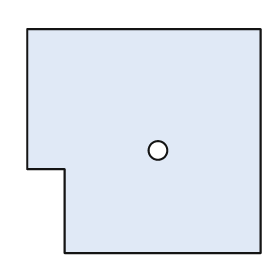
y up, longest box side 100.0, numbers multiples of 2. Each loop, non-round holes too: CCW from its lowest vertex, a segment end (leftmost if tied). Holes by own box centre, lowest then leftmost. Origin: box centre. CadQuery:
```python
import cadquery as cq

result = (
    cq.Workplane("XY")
    .moveTo(-34.0, -48.0)
    .lineTo(50.0, -48.0)
    .lineTo(50.0, 48.0)
    .lineTo(-50.0, 48.0)
    .lineTo(-50.0, -12.0)
    .lineTo(-34.0, -12.0)
    .close()
    .moveTo(6.0, -4.0)
    .circle(4.0)
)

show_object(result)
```